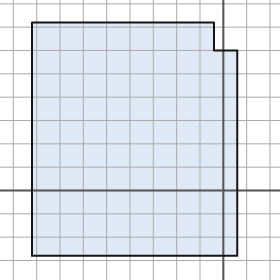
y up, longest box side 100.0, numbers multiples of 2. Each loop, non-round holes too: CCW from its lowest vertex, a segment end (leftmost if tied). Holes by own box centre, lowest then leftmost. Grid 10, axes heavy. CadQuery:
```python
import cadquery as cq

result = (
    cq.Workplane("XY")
    .moveTo(-82.0, -28.0)
    .lineTo(6.0, -28.0)
    .lineTo(6.0, 60.0)
    .lineTo(-4.0, 60.0)
    .lineTo(-4.0, 72.0)
    .lineTo(-82.0, 72.0)
    .close()
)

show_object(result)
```